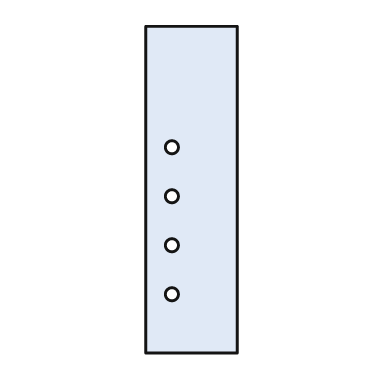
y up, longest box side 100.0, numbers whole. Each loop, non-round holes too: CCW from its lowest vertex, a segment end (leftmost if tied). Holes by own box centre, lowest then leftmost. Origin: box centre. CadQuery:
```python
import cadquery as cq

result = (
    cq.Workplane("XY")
    .moveTo(-14.0, -50.0)
    .lineTo(14.0, -50.0)
    .lineTo(14.0, 50.0)
    .lineTo(-14.0, 50.0)
    .close()
    .moveTo(-6.0, -32.0)
    .circle(2.0)
    .moveTo(-6.0, -17.0)
    .circle(2.0)
    .moveTo(-6.0, -2.0)
    .circle(2.0)
    .moveTo(-6.0, 13.0)
    .circle(2.0)
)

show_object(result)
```